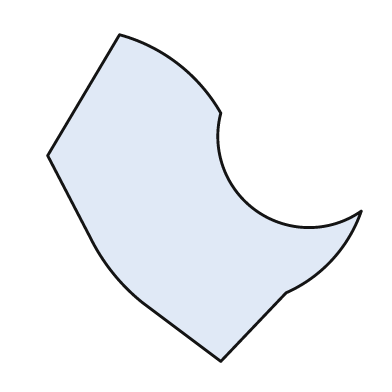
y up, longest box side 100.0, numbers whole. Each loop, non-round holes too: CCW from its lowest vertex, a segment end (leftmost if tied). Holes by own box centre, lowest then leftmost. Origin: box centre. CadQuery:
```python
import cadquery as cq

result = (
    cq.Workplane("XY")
    .moveTo(5.0, -50.0)
    .lineTo(25.0, -29.0)
    .threePointArc((39.0, -19.0), (48.0, -4.0))
    .threePointArc((16.0, -4.0), (5.0, 26.0))
    .threePointArc((-8.0, 41.0), (-26.0, 50.0))
    .lineTo(-48.0, 13.0)
    .lineTo(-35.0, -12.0)
    .threePointArc((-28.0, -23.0), (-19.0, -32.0))
    .close()
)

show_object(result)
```